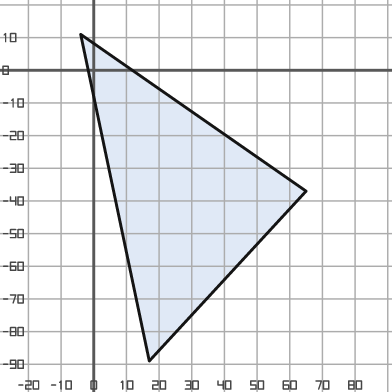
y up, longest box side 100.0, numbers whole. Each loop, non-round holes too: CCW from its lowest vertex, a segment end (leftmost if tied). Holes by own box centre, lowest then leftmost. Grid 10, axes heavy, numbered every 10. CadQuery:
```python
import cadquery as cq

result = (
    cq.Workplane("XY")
    .moveTo(17.0, -89.0)
    .lineTo(65.0, -37.0)
    .lineTo(-4.0, 11.0)
    .close()
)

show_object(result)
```